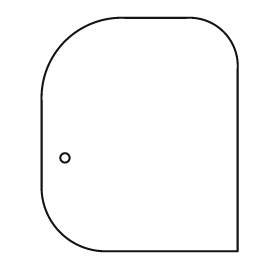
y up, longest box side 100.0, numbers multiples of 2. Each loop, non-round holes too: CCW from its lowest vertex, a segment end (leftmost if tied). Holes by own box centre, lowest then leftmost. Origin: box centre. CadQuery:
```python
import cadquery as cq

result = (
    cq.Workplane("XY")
    .moveTo(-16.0, -50.0)
    .lineTo(42.0, -50.0)
    .lineTo(42.0, 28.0)
    .threePointArc((36.0, 44.0), (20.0, 50.0))
    .lineTo(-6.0, 50.0)
    .threePointArc((-32.0, 40.0), (-42.0, 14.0))
    .lineTo(-42.0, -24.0)
    .threePointArc((-34.0, -42.0), (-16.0, -50.0))
    .close()
    .moveTo(-32.0, -10.0)
    .circle(2.0)
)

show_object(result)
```